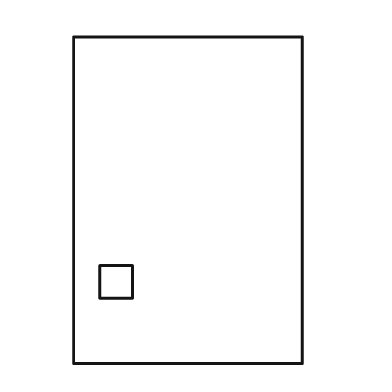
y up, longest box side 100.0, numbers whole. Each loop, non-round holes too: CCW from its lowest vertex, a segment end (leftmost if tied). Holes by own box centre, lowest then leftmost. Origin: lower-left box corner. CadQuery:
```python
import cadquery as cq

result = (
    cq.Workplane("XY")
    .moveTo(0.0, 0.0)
    .lineTo(70.0, 0.0)
    .lineTo(70.0, 100.0)
    .lineTo(0.0, 100.0)
    .close()
    .moveTo(8.0, 20.0)
    .lineTo(18.0, 20.0)
    .lineTo(18.0, 30.0)
    .lineTo(8.0, 30.0)
    .close()
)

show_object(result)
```